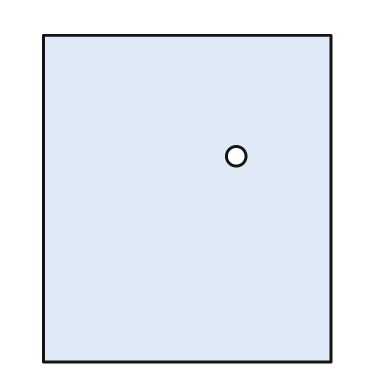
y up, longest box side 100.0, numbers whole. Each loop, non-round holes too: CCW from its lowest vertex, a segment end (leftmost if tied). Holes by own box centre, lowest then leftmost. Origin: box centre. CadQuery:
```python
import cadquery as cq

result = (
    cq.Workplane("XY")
    .moveTo(-44.0, -50.0)
    .lineTo(44.0, -50.0)
    .lineTo(44.0, 50.0)
    .lineTo(-44.0, 50.0)
    .close()
    .moveTo(15.0, 13.0)
    .circle(3.0)
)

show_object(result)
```